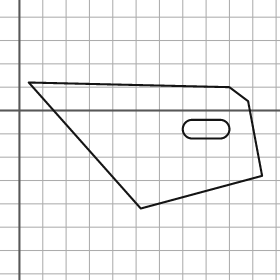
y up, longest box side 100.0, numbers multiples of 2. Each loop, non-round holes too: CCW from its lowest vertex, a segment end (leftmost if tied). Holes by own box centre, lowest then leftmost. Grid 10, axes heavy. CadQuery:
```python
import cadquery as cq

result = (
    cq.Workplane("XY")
    .moveTo(52.0, -42.0)
    .lineTo(104.0, -28.0)
    .lineTo(98.0, 4.0)
    .lineTo(90.0, 10.0)
    .lineTo(4.0, 12.0)
    .close()
    .moveTo(74.0, -12.0)
    .lineTo(86.0, -12.0)
    .threePointArc((90.0, -8.0), (86.0, -4.0))
    .lineTo(74.0, -4.0)
    .threePointArc((70.0, -8.0), (74.0, -12.0))
    .close()
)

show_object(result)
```